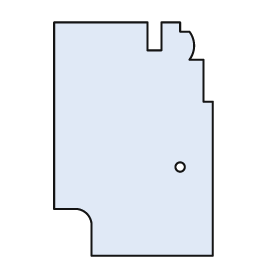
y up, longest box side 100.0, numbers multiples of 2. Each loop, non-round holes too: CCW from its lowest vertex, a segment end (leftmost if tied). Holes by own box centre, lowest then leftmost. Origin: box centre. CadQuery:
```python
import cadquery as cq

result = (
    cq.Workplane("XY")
    .moveTo(-18.0, -50.0)
    .lineTo(34.0, -50.0)
    .lineTo(34.0, 16.0)
    .lineTo(30.0, 16.0)
    .lineTo(30.0, 34.0)
    .lineTo(24.0, 34.0)
    .threePointArc((26.0, 40.0), (24.0, 46.0))
    .lineTo(20.0, 46.0)
    .lineTo(20.0, 50.0)
    .lineTo(12.0, 50.0)
    .lineTo(12.0, 38.0)
    .lineTo(6.0, 38.0)
    .lineTo(6.0, 50.0)
    .lineTo(-34.0, 50.0)
    .lineTo(-34.0, -30.0)
    .lineTo(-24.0, -30.0)
    .threePointArc((-20.0, -32.0), (-18.0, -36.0))
    .close()
    .moveTo(20.0, -12.0)
    .circle(2.0)
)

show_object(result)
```